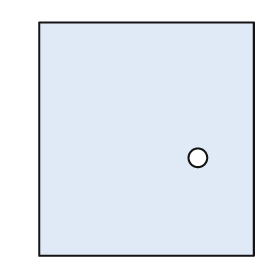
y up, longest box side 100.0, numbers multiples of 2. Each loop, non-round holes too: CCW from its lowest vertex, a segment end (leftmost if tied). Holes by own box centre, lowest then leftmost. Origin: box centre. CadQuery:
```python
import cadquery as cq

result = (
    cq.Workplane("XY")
    .moveTo(-46.0, -50.0)
    .lineTo(46.0, -50.0)
    .lineTo(46.0, 50.0)
    .lineTo(-46.0, 50.0)
    .close()
    .moveTo(22.0, -8.0)
    .circle(4.0)
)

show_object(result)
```